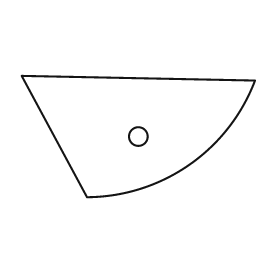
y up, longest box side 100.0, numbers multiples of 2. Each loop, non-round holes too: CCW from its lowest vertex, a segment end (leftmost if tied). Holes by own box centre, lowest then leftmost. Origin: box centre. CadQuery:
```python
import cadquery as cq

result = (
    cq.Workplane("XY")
    .moveTo(-22.0, -26.0)
    .threePointArc((22.0, -12.0), (50.0, 24.0))
    .lineTo(-50.0, 26.0)
    .close()
    .moveTo(0.0, 0.0)
    .circle(4.0)
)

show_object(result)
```